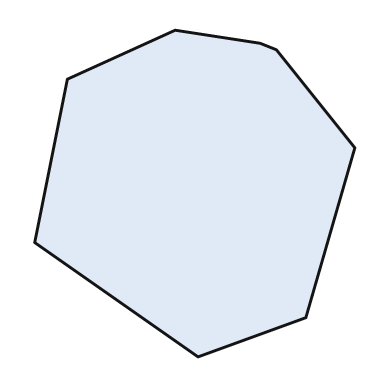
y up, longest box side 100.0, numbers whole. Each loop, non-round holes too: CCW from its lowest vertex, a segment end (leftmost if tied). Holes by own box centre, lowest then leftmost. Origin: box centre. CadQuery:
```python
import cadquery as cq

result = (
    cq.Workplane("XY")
    .moveTo(1.0, -50.0)
    .lineTo(34.0, -38.0)
    .lineTo(49.0, 14.0)
    .lineTo(25.0, 44.0)
    .lineTo(20.0, 46.0)
    .lineTo(-6.0, 50.0)
    .lineTo(-39.0, 35.0)
    .lineTo(-49.0, -15.0)
    .close()
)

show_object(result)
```